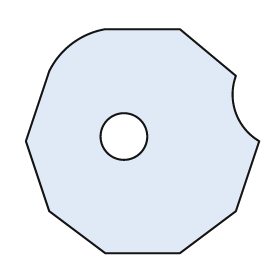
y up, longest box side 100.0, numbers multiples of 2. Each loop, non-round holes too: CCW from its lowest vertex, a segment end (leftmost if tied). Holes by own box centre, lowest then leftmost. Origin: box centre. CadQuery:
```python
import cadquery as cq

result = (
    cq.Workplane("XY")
    .moveTo(-16.0, -48.0)
    .lineTo(16.0, -48.0)
    .lineTo(40.0, -30.0)
    .lineTo(50.0, 0.0)
    .threePointArc((40.0, 12.0), (40.0, 28.0))
    .lineTo(16.0, 48.0)
    .lineTo(-16.0, 48.0)
    .threePointArc((-30.0, 42.0), (-40.0, 30.0))
    .lineTo(-50.0, 0.0)
    .lineTo(-40.0, -30.0)
    .close()
    .moveTo(-8.0, 2.0)
    .circle(10.0)
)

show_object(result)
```